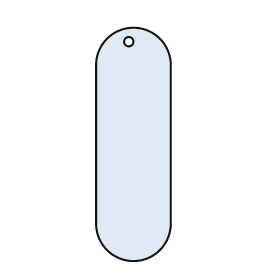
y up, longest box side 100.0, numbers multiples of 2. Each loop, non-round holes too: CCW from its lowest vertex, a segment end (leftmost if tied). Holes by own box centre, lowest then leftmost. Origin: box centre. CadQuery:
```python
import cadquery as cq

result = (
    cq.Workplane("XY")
    .moveTo(-16.0, -34.0)
    .threePointArc((0.0, -50.0), (16.0, -34.0))
    .lineTo(16.0, 34.0)
    .threePointArc((0.0, 50.0), (-16.0, 34.0))
    .close()
    .moveTo(-2.0, 44.0)
    .circle(2.0)
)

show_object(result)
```